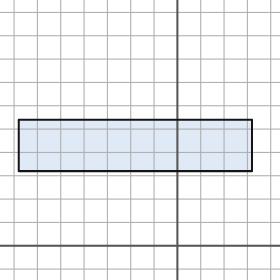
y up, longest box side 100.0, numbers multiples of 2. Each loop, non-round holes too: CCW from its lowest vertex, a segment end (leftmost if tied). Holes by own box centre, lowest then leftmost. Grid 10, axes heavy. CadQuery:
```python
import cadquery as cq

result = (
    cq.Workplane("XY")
    .moveTo(-68.0, 32.0)
    .lineTo(32.0, 32.0)
    .lineTo(32.0, 54.0)
    .lineTo(-68.0, 54.0)
    .close()
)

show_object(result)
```